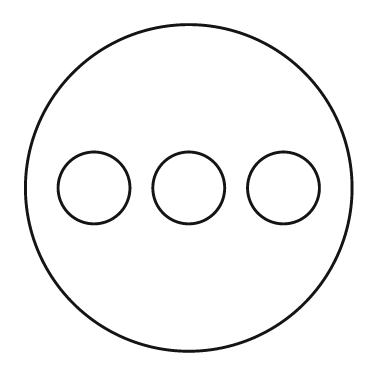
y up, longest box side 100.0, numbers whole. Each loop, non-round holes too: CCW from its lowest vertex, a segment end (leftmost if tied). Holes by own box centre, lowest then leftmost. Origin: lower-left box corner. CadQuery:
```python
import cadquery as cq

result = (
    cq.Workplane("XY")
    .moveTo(50.0, 50.0)
    .circle(50.0)
    .moveTo(21.0, 50.0)
    .circle(11.0)
    .moveTo(50.0, 50.0)
    .circle(11.0)
    .moveTo(79.0, 50.0)
    .circle(11.0)
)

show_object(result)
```